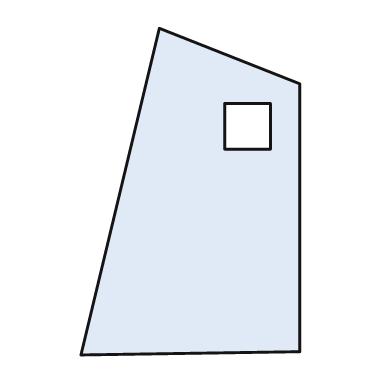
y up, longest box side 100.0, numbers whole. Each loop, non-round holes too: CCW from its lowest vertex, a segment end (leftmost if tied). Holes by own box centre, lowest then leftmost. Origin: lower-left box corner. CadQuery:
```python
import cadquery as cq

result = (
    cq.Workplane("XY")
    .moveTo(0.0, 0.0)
    .lineTo(67.0, 1.0)
    .lineTo(67.0, 83.0)
    .lineTo(24.0, 100.0)
    .close()
    .moveTo(44.0, 63.0)
    .lineTo(58.0, 63.0)
    .lineTo(58.0, 77.0)
    .lineTo(44.0, 77.0)
    .close()
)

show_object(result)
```